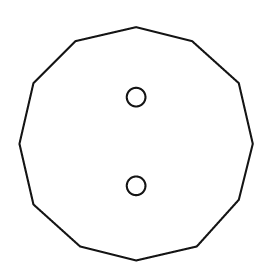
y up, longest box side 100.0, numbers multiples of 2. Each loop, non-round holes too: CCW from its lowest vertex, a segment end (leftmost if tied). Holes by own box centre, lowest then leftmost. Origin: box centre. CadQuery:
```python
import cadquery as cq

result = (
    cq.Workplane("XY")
    .moveTo(0.0, -50.0)
    .lineTo(26.0, -44.0)
    .lineTo(44.0, -24.0)
    .lineTo(50.0, 0.0)
    .lineTo(44.0, 26.0)
    .lineTo(24.0, 44.0)
    .lineTo(0.0, 50.0)
    .lineTo(-26.0, 44.0)
    .lineTo(-44.0, 26.0)
    .lineTo(-50.0, 0.0)
    .lineTo(-44.0, -26.0)
    .lineTo(-24.0, -44.0)
    .close()
    .moveTo(0.0, -18.0)
    .circle(4.0)
    .moveTo(0.0, 20.0)
    .circle(4.0)
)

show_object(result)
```